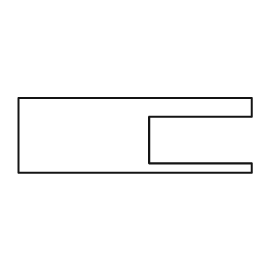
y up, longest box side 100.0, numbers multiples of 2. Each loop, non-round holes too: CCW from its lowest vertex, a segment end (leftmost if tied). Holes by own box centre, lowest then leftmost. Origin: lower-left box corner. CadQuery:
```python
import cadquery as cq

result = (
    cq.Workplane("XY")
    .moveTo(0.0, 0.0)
    .lineTo(100.0, 0.0)
    .lineTo(100.0, 4.0)
    .lineTo(56.0, 4.0)
    .lineTo(56.0, 24.0)
    .lineTo(100.0, 24.0)
    .lineTo(100.0, 32.0)
    .lineTo(0.0, 32.0)
    .close()
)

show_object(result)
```